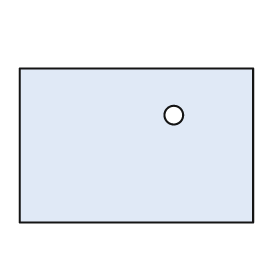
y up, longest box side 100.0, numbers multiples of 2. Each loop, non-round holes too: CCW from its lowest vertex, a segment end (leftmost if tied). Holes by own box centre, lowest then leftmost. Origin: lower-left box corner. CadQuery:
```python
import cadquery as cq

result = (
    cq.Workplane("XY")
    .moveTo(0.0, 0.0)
    .lineTo(100.0, 0.0)
    .lineTo(100.0, 66.0)
    .lineTo(0.0, 66.0)
    .close()
    .moveTo(66.0, 46.0)
    .circle(4.0)
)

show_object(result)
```